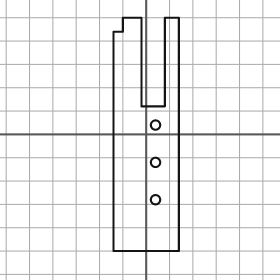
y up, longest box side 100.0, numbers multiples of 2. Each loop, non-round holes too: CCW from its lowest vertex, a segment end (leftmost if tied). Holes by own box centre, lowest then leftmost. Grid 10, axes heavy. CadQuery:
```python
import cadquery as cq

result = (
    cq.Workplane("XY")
    .moveTo(-14.0, -50.0)
    .lineTo(14.0, -50.0)
    .lineTo(14.0, 50.0)
    .lineTo(8.0, 50.0)
    .lineTo(8.0, 12.0)
    .lineTo(-2.0, 12.0)
    .lineTo(-2.0, 50.0)
    .lineTo(-10.0, 50.0)
    .lineTo(-10.0, 44.0)
    .lineTo(-14.0, 44.0)
    .close()
    .moveTo(4.0, -28.0)
    .circle(2.0)
    .moveTo(4.0, -12.0)
    .circle(2.0)
    .moveTo(4.0, 4.0)
    .circle(2.0)
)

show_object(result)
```